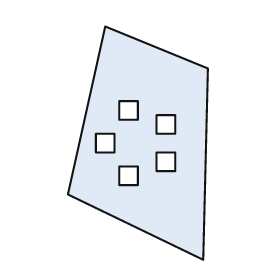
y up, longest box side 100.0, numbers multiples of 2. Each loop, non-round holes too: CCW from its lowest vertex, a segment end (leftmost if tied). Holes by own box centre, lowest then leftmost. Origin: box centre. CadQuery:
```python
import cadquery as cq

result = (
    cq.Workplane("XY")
    .moveTo(28.0, -50.0)
    .lineTo(30.0, 32.0)
    .lineTo(-14.0, 50.0)
    .lineTo(-30.0, -22.0)
    .close()
    .moveTo(-8.0, -18.0)
    .lineTo(0.0, -18.0)
    .lineTo(0.0, -10.0)
    .lineTo(-8.0, -10.0)
    .close()
    .moveTo(8.0, -12.0)
    .lineTo(16.0, -12.0)
    .lineTo(16.0, -4.0)
    .lineTo(8.0, -4.0)
    .close()
    .moveTo(-18.0, -4.0)
    .lineTo(-10.0, -4.0)
    .lineTo(-10.0, 4.0)
    .lineTo(-18.0, 4.0)
    .close()
    .moveTo(8.0, 4.0)
    .lineTo(16.0, 4.0)
    .lineTo(16.0, 12.0)
    .lineTo(8.0, 12.0)
    .close()
    .moveTo(-8.0, 10.0)
    .lineTo(0.0, 10.0)
    .lineTo(0.0, 18.0)
    .lineTo(-8.0, 18.0)
    .close()
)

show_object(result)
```